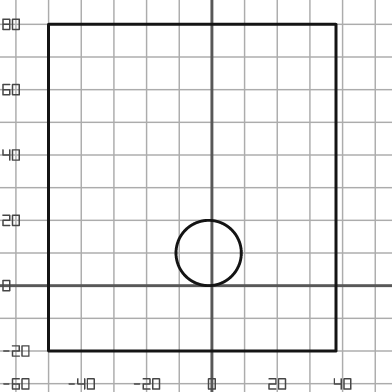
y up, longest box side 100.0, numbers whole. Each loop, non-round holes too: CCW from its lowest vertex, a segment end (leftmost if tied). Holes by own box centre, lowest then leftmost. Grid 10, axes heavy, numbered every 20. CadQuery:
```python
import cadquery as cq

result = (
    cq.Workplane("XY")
    .moveTo(-50.0, -20.0)
    .lineTo(38.0, -20.0)
    .lineTo(38.0, 80.0)
    .lineTo(-50.0, 80.0)
    .close()
    .moveTo(-1.0, 10.0)
    .circle(10.0)
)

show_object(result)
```